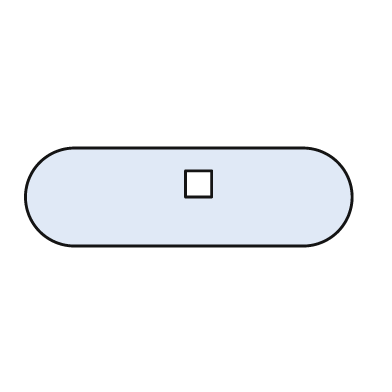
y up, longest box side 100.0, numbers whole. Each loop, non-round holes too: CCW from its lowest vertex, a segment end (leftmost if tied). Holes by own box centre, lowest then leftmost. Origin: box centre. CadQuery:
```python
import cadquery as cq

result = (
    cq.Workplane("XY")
    .moveTo(-35.0, -15.0)
    .lineTo(35.0, -15.0)
    .threePointArc((50.0, 0.0), (35.0, 15.0))
    .lineTo(-35.0, 15.0)
    .threePointArc((-50.0, 0.0), (-35.0, -15.0))
    .close()
    .moveTo(-1.0, 0.0)
    .lineTo(7.0, 0.0)
    .lineTo(7.0, 8.0)
    .lineTo(-1.0, 8.0)
    .close()
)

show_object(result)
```